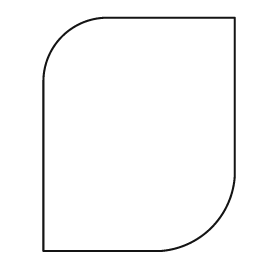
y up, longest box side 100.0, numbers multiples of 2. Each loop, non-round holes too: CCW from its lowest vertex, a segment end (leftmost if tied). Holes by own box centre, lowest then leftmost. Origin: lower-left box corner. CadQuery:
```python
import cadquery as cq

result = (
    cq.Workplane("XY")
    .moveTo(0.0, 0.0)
    .lineTo(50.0, 0.0)
    .threePointArc((72.0, 10.0), (82.0, 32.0))
    .lineTo(82.0, 100.0)
    .lineTo(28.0, 100.0)
    .threePointArc((8.0, 92.0), (0.0, 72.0))
    .close()
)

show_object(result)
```